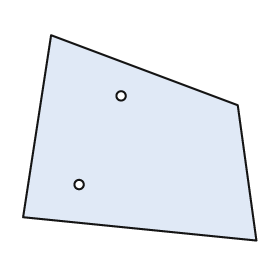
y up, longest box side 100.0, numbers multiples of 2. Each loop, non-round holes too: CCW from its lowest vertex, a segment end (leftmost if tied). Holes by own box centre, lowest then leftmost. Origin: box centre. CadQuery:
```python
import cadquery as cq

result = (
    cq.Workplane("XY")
    .moveTo(50.0, -44.0)
    .lineTo(42.0, 14.0)
    .lineTo(-38.0, 44.0)
    .lineTo(-50.0, -34.0)
    .close()
    .moveTo(-26.0, -20.0)
    .circle(2.0)
    .moveTo(-8.0, 18.0)
    .circle(2.0)
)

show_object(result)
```